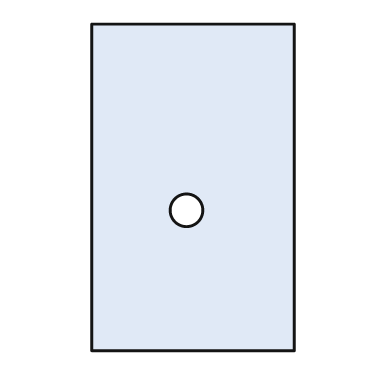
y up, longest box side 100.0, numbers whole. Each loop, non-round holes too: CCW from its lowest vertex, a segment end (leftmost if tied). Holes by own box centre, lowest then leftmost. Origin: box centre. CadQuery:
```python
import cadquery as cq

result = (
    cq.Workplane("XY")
    .moveTo(-31.0, -50.0)
    .lineTo(31.0, -50.0)
    .lineTo(31.0, 50.0)
    .lineTo(-31.0, 50.0)
    .close()
    .moveTo(-2.0, -7.0)
    .circle(5.0)
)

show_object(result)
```